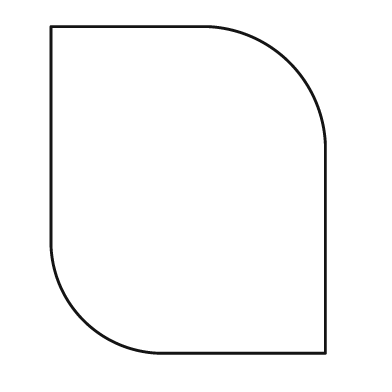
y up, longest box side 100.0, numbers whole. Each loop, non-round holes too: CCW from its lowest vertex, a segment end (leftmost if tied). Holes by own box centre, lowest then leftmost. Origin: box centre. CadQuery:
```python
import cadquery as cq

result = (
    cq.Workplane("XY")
    .moveTo(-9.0, -50.0)
    .lineTo(42.0, -50.0)
    .lineTo(42.0, 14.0)
    .threePointArc((31.0, 39.0), (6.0, 50.0))
    .lineTo(-42.0, 50.0)
    .lineTo(-42.0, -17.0)
    .threePointArc((-32.0, -40.0), (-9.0, -50.0))
    .close()
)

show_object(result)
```